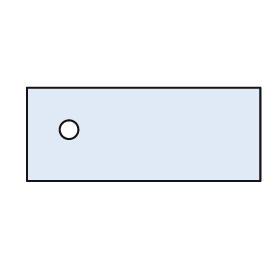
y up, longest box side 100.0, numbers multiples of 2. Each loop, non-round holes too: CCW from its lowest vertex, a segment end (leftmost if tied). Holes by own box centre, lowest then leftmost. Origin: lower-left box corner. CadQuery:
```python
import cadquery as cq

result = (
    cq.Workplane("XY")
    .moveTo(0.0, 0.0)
    .lineTo(100.0, 0.0)
    .lineTo(100.0, 40.0)
    .lineTo(0.0, 40.0)
    .close()
    .moveTo(18.0, 22.0)
    .circle(4.0)
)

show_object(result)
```